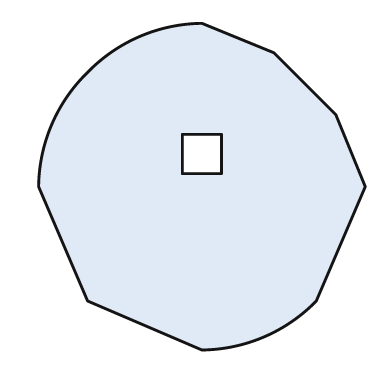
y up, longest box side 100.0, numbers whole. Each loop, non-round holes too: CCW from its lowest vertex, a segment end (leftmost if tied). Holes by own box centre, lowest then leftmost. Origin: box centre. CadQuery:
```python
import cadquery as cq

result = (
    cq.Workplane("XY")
    .moveTo(0.0, -50.0)
    .threePointArc((19.0, -46.0), (35.0, -35.0))
    .lineTo(50.0, 0.0)
    .lineTo(41.0, 22.0)
    .lineTo(22.0, 41.0)
    .lineTo(0.0, 50.0)
    .threePointArc((-19.0, 46.0), (-35.0, 35.0))
    .threePointArc((-46.0, 19.0), (-50.0, 0.0))
    .lineTo(-35.0, -35.0)
    .close()
    .moveTo(-6.0, 4.0)
    .lineTo(6.0, 4.0)
    .lineTo(6.0, 16.0)
    .lineTo(-6.0, 16.0)
    .close()
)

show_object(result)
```